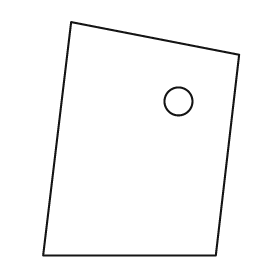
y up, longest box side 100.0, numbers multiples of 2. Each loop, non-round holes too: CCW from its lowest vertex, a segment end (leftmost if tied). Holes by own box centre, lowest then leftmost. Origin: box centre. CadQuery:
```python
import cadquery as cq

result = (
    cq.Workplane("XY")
    .moveTo(-42.0, -50.0)
    .lineTo(32.0, -50.0)
    .lineTo(42.0, 36.0)
    .lineTo(-30.0, 50.0)
    .close()
    .moveTo(16.0, 16.0)
    .circle(6.0)
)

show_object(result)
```